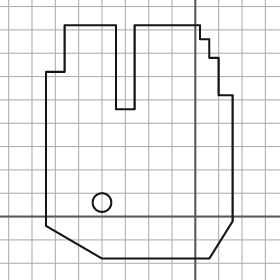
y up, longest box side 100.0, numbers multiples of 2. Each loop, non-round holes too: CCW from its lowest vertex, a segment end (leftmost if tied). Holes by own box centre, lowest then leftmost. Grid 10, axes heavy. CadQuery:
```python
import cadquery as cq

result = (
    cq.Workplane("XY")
    .moveTo(-40.0, -18.0)
    .lineTo(6.0, -18.0)
    .lineTo(16.0, -2.0)
    .lineTo(16.0, 52.0)
    .lineTo(10.0, 52.0)
    .lineTo(10.0, 68.0)
    .lineTo(6.0, 68.0)
    .lineTo(6.0, 76.0)
    .lineTo(2.0, 76.0)
    .lineTo(2.0, 82.0)
    .lineTo(-26.0, 82.0)
    .lineTo(-26.0, 46.0)
    .lineTo(-34.0, 46.0)
    .lineTo(-34.0, 82.0)
    .lineTo(-56.0, 82.0)
    .lineTo(-56.0, 62.0)
    .lineTo(-64.0, 62.0)
    .lineTo(-64.0, -4.0)
    .close()
    .moveTo(-40.0, 6.0)
    .circle(4.0)
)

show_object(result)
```